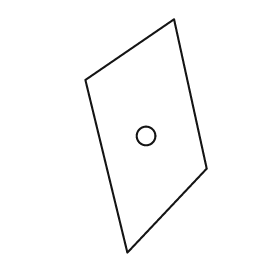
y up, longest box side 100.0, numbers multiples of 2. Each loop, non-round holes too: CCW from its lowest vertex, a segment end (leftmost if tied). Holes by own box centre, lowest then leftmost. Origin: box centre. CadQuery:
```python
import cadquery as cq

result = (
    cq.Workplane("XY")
    .moveTo(-8.0, -50.0)
    .lineTo(26.0, -14.0)
    .lineTo(12.0, 50.0)
    .lineTo(-26.0, 24.0)
    .close()
    .moveTo(0.0, 0.0)
    .circle(4.0)
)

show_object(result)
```